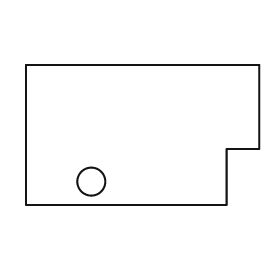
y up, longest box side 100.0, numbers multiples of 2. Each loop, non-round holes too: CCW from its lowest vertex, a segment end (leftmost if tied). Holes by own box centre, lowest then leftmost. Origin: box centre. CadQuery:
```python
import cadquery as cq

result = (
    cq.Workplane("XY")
    .moveTo(-50.0, -30.0)
    .lineTo(36.0, -30.0)
    .lineTo(36.0, -6.0)
    .lineTo(50.0, -6.0)
    .lineTo(50.0, 30.0)
    .lineTo(-50.0, 30.0)
    .close()
    .moveTo(-22.0, -20.0)
    .circle(6.0)
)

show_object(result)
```